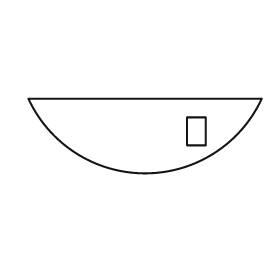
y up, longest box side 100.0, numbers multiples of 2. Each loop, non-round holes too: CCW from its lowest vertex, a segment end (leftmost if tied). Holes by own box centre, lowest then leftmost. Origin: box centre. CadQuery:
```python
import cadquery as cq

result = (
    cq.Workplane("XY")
    .moveTo(-50.0, 16.0)
    .threePointArc((0.0, -16.0), (50.0, 16.0))
    .close()
    .moveTo(18.0, -4.0)
    .lineTo(26.0, -4.0)
    .lineTo(26.0, 8.0)
    .lineTo(18.0, 8.0)
    .close()
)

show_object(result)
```